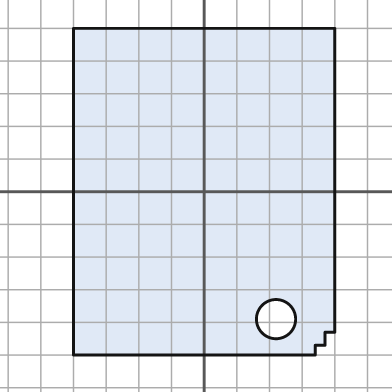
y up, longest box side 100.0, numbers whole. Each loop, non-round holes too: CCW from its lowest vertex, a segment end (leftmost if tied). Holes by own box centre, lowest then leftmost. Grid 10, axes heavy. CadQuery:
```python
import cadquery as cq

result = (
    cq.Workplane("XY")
    .moveTo(-40.0, -50.0)
    .lineTo(34.0, -50.0)
    .lineTo(34.0, -47.0)
    .lineTo(37.0, -47.0)
    .lineTo(37.0, -43.0)
    .lineTo(40.0, -43.0)
    .lineTo(40.0, 50.0)
    .lineTo(-40.0, 50.0)
    .close()
    .moveTo(22.0, -39.0)
    .circle(6.0)
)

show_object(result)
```